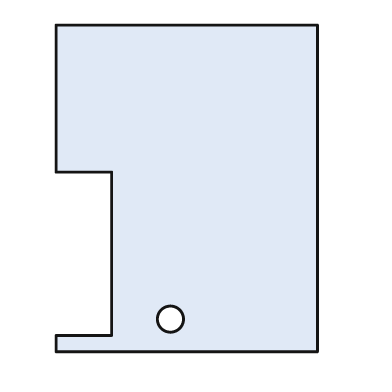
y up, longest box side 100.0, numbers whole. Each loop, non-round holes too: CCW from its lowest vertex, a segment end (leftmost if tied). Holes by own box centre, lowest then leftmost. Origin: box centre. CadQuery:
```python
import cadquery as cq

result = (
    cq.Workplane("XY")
    .moveTo(-40.0, -50.0)
    .lineTo(40.0, -50.0)
    .lineTo(40.0, 50.0)
    .lineTo(-40.0, 50.0)
    .lineTo(-40.0, 5.0)
    .lineTo(-23.0, 5.0)
    .lineTo(-23.0, -45.0)
    .lineTo(-40.0, -45.0)
    .close()
    .moveTo(-5.0, -40.0)
    .circle(4.0)
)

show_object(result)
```